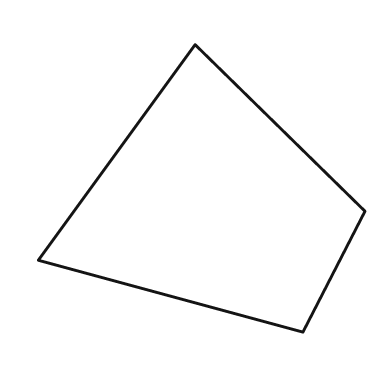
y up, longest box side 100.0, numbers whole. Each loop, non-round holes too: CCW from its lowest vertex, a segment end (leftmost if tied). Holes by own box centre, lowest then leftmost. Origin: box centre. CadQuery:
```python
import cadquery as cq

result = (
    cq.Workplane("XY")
    .moveTo(31.0, -44.0)
    .lineTo(50.0, -7.0)
    .lineTo(-2.0, 44.0)
    .lineTo(-50.0, -22.0)
    .close()
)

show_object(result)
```